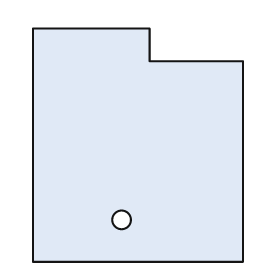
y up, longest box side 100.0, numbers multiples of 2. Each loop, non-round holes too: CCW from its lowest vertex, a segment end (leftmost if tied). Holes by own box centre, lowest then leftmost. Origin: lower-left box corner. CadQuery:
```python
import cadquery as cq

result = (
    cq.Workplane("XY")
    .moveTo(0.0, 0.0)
    .lineTo(90.0, 0.0)
    .lineTo(90.0, 86.0)
    .lineTo(50.0, 86.0)
    .lineTo(50.0, 100.0)
    .lineTo(0.0, 100.0)
    .close()
    .moveTo(38.0, 18.0)
    .circle(4.0)
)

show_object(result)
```